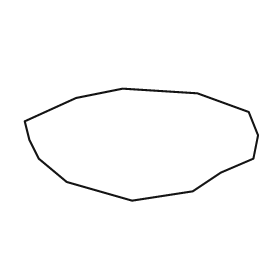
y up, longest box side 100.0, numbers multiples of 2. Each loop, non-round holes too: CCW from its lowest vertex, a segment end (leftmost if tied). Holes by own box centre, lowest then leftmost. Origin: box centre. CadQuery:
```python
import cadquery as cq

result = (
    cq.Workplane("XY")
    .moveTo(-4.0, -24.0)
    .lineTo(22.0, -20.0)
    .lineTo(34.0, -12.0)
    .lineTo(48.0, -6.0)
    .lineTo(50.0, 4.0)
    .lineTo(46.0, 14.0)
    .lineTo(24.0, 22.0)
    .lineTo(-8.0, 24.0)
    .lineTo(-28.0, 20.0)
    .lineTo(-50.0, 10.0)
    .lineTo(-48.0, 2.0)
    .lineTo(-44.0, -6.0)
    .lineTo(-32.0, -16.0)
    .close()
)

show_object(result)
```